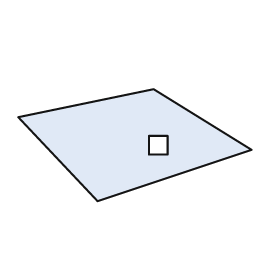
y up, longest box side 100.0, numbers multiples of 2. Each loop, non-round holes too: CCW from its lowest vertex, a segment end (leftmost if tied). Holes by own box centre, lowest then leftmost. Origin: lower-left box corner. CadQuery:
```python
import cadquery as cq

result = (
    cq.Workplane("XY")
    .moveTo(34.0, 0.0)
    .lineTo(100.0, 22.0)
    .lineTo(58.0, 48.0)
    .lineTo(0.0, 36.0)
    .close()
    .moveTo(56.0, 20.0)
    .lineTo(64.0, 20.0)
    .lineTo(64.0, 28.0)
    .lineTo(56.0, 28.0)
    .close()
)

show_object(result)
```